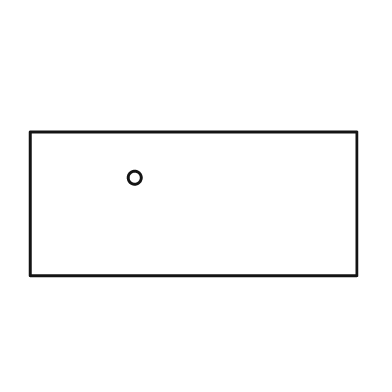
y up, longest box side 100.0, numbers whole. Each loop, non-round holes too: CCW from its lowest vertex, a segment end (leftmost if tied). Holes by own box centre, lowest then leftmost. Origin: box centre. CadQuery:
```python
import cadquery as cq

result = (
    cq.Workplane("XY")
    .moveTo(-50.0, -22.0)
    .lineTo(50.0, -22.0)
    .lineTo(50.0, 22.0)
    .lineTo(-50.0, 22.0)
    .close()
    .moveTo(-18.0, 8.0)
    .circle(2.0)
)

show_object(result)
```